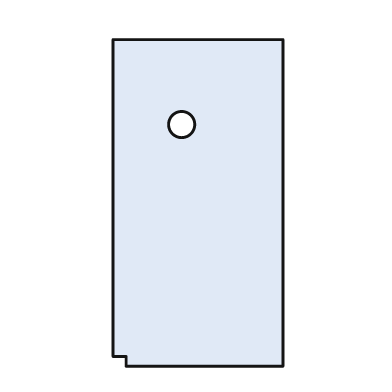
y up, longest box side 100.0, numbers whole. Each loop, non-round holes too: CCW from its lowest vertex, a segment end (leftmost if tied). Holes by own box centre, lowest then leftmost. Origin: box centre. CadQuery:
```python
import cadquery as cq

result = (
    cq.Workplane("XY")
    .moveTo(-22.0, -50.0)
    .lineTo(26.0, -50.0)
    .lineTo(26.0, 50.0)
    .lineTo(-26.0, 50.0)
    .lineTo(-26.0, -47.0)
    .lineTo(-22.0, -47.0)
    .close()
    .moveTo(-5.0, 24.0)
    .circle(4.0)
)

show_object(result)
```